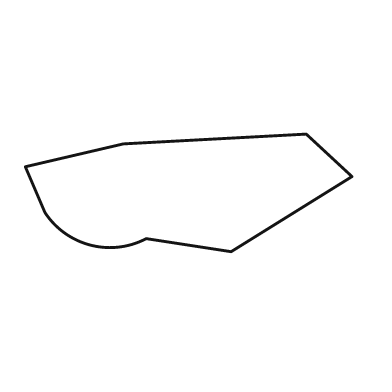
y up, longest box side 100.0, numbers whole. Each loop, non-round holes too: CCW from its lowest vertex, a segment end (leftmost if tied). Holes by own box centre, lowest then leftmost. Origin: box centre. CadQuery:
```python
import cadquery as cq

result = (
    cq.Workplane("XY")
    .moveTo(13.0, -18.0)
    .lineTo(50.0, 5.0)
    .lineTo(36.0, 18.0)
    .lineTo(-20.0, 15.0)
    .lineTo(-50.0, 8.0)
    .lineTo(-44.0, -6.0)
    .threePointArc((-30.0, -16.0), (-13.0, -14.0))
    .close()
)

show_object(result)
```